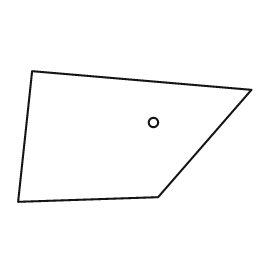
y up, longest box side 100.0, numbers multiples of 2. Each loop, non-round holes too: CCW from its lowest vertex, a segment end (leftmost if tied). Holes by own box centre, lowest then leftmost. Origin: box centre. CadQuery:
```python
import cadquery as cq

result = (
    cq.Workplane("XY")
    .moveTo(-50.0, -28.0)
    .lineTo(10.0, -26.0)
    .lineTo(50.0, 20.0)
    .lineTo(-44.0, 28.0)
    .close()
    .moveTo(8.0, 6.0)
    .circle(2.0)
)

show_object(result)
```